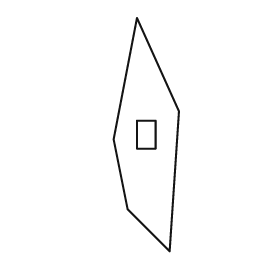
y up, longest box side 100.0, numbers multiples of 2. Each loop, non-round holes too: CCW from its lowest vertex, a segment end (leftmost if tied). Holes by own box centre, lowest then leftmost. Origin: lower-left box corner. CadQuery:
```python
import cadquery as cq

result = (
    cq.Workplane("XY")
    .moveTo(24.0, 0.0)
    .lineTo(28.0, 60.0)
    .lineTo(10.0, 100.0)
    .lineTo(0.0, 48.0)
    .lineTo(6.0, 18.0)
    .close()
    .moveTo(10.0, 44.0)
    .lineTo(18.0, 44.0)
    .lineTo(18.0, 56.0)
    .lineTo(10.0, 56.0)
    .close()
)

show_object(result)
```